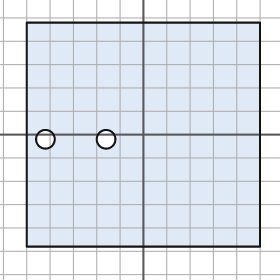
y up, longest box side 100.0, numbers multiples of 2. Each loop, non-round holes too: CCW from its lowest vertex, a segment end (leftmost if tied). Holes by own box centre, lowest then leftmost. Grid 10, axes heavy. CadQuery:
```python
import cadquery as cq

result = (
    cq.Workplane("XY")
    .moveTo(-50.0, -48.0)
    .lineTo(50.0, -48.0)
    .lineTo(50.0, 48.0)
    .lineTo(-50.0, 48.0)
    .close()
    .moveTo(-42.0, -2.0)
    .circle(4.0)
    .moveTo(-16.0, -2.0)
    .circle(4.0)
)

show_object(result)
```